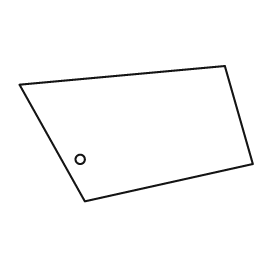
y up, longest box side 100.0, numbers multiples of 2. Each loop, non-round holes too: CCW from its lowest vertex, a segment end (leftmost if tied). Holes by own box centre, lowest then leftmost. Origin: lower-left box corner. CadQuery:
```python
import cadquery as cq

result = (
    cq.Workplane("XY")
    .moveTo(28.0, 0.0)
    .lineTo(100.0, 16.0)
    .lineTo(88.0, 58.0)
    .lineTo(0.0, 50.0)
    .close()
    .moveTo(26.0, 18.0)
    .circle(2.0)
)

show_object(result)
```